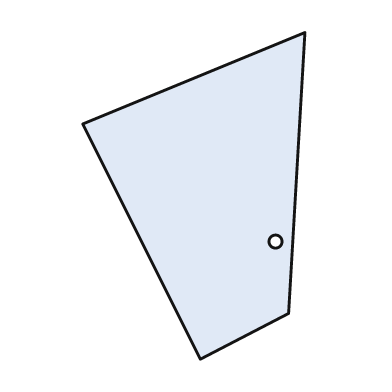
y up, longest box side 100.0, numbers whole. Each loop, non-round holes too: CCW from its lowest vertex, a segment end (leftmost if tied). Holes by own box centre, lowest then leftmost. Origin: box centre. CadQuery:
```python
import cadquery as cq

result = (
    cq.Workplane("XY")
    .moveTo(2.0, -50.0)
    .lineTo(29.0, -36.0)
    .lineTo(34.0, 50.0)
    .lineTo(-34.0, 22.0)
    .close()
    .moveTo(25.0, -14.0)
    .circle(2.0)
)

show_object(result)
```